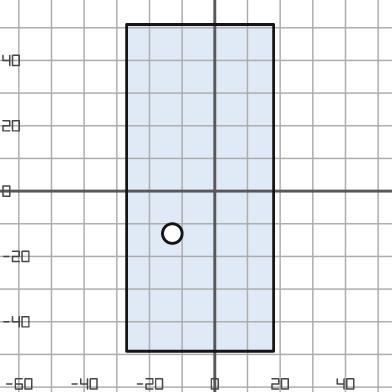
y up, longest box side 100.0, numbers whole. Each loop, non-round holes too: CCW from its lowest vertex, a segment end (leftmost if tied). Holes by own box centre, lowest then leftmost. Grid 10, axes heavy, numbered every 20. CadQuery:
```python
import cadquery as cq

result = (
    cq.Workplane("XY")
    .moveTo(-27.0, -49.0)
    .lineTo(18.0, -49.0)
    .lineTo(18.0, 51.0)
    .lineTo(-27.0, 51.0)
    .close()
    .moveTo(-13.0, -13.0)
    .circle(3.0)
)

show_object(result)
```